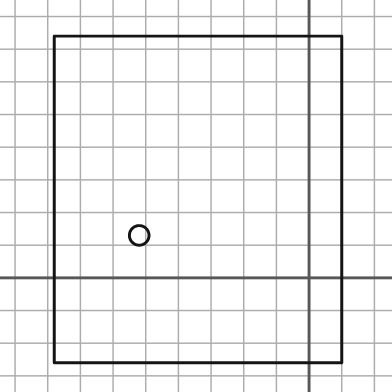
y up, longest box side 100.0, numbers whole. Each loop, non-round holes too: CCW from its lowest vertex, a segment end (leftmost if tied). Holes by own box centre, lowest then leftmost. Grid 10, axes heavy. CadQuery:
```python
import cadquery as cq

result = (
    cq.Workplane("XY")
    .moveTo(-78.0, -26.0)
    .lineTo(10.0, -26.0)
    .lineTo(10.0, 74.0)
    .lineTo(-78.0, 74.0)
    .close()
    .moveTo(-52.0, 13.0)
    .circle(3.0)
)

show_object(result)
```